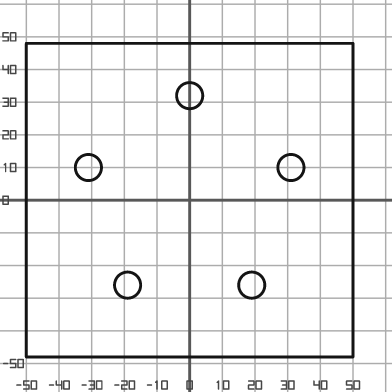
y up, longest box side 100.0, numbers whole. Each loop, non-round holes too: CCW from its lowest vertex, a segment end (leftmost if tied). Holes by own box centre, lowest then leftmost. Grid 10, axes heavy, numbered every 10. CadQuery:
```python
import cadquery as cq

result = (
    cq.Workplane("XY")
    .moveTo(-50.0, -48.0)
    .lineTo(50.0, -48.0)
    .lineTo(50.0, 48.0)
    .lineTo(-50.0, 48.0)
    .close()
    .moveTo(-19.0, -26.0)
    .circle(4.0)
    .moveTo(19.0, -26.0)
    .circle(4.0)
    .moveTo(-31.0, 10.0)
    .circle(4.0)
    .moveTo(31.0, 10.0)
    .circle(4.0)
    .moveTo(0.0, 32.0)
    .circle(4.0)
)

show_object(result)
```